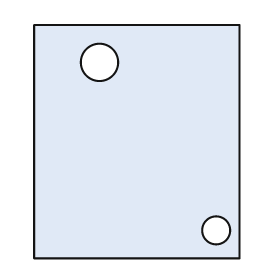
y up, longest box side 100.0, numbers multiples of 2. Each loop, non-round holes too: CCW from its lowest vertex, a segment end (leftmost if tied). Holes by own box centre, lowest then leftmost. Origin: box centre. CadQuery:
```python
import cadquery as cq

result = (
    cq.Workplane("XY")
    .moveTo(-44.0, -50.0)
    .lineTo(44.0, -50.0)
    .lineTo(44.0, 50.0)
    .lineTo(-44.0, 50.0)
    .close()
    .moveTo(34.0, -38.0)
    .circle(6.0)
    .moveTo(-16.0, 34.0)
    .circle(8.0)
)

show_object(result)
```